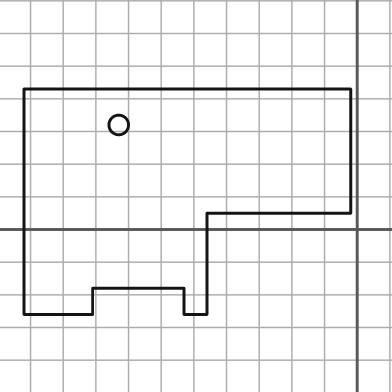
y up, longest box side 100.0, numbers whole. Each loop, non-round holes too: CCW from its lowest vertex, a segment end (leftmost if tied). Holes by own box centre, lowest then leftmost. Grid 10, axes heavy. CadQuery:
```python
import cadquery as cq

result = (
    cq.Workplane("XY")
    .moveTo(-102.0, -26.0)
    .lineTo(-81.0, -26.0)
    .lineTo(-81.0, -18.0)
    .lineTo(-53.0, -18.0)
    .lineTo(-53.0, -26.0)
    .lineTo(-46.0, -26.0)
    .lineTo(-46.0, 5.0)
    .lineTo(-2.0, 5.0)
    .lineTo(-2.0, 43.0)
    .lineTo(-102.0, 43.0)
    .close()
    .moveTo(-73.0, 32.0)
    .circle(3.0)
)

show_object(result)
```